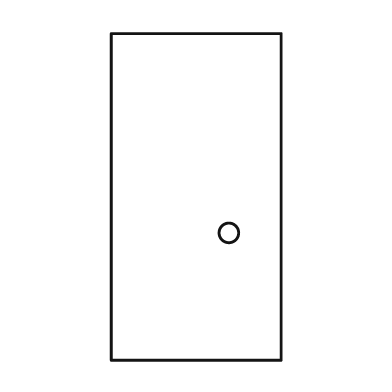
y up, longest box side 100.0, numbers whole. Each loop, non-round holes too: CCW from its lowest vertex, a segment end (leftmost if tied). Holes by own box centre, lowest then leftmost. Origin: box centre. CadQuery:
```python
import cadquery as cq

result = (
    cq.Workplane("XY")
    .moveTo(-26.0, -50.0)
    .lineTo(26.0, -50.0)
    .lineTo(26.0, 50.0)
    .lineTo(-26.0, 50.0)
    .close()
    .moveTo(10.0, -11.0)
    .circle(3.0)
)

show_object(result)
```